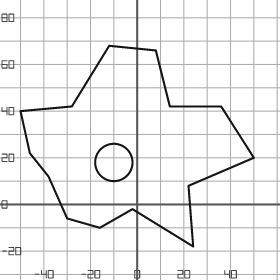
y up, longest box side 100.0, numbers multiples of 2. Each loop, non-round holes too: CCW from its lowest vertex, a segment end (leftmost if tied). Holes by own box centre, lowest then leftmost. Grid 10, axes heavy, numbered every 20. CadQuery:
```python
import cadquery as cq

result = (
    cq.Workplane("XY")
    .moveTo(24.0, -18.0)
    .lineTo(22.0, 8.0)
    .lineTo(50.0, 20.0)
    .lineTo(36.0, 42.0)
    .lineTo(14.0, 42.0)
    .lineTo(8.0, 66.0)
    .lineTo(-12.0, 68.0)
    .lineTo(-28.0, 42.0)
    .lineTo(-50.0, 40.0)
    .lineTo(-46.0, 22.0)
    .lineTo(-38.0, 12.0)
    .lineTo(-30.0, -6.0)
    .lineTo(-16.0, -10.0)
    .lineTo(-2.0, -2.0)
    .close()
    .moveTo(-10.0, 18.0)
    .circle(8.0)
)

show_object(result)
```